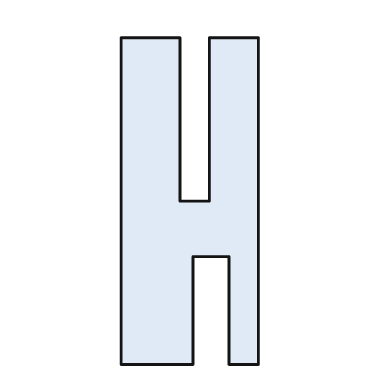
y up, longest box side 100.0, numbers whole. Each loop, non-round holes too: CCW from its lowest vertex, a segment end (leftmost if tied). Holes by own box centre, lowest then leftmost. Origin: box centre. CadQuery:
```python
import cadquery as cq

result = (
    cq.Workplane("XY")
    .moveTo(-21.0, -50.0)
    .lineTo(1.0, -50.0)
    .lineTo(1.0, -17.0)
    .lineTo(12.0, -17.0)
    .lineTo(12.0, -50.0)
    .lineTo(21.0, -50.0)
    .lineTo(21.0, 50.0)
    .lineTo(6.0, 50.0)
    .lineTo(6.0, 0.0)
    .lineTo(-3.0, 0.0)
    .lineTo(-3.0, 50.0)
    .lineTo(-21.0, 50.0)
    .close()
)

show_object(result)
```